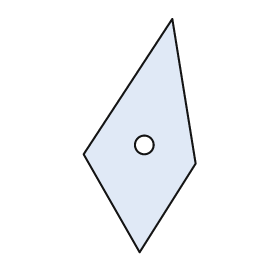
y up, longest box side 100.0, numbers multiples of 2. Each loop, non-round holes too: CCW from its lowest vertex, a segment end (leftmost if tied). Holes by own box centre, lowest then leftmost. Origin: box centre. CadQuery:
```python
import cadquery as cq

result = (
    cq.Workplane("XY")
    .moveTo(0.0, -50.0)
    .lineTo(24.0, -12.0)
    .lineTo(14.0, 50.0)
    .lineTo(-24.0, -8.0)
    .close()
    .moveTo(2.0, -4.0)
    .circle(4.0)
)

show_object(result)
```